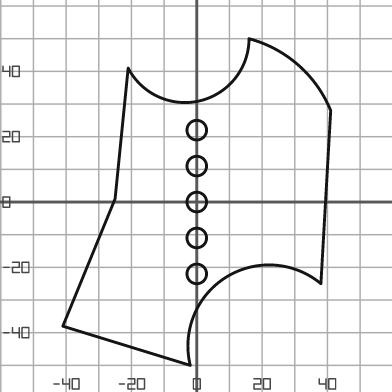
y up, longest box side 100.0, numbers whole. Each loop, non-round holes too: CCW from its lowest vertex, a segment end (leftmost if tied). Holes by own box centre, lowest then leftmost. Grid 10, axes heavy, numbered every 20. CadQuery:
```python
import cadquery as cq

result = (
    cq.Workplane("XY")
    .moveTo(-2.0, -50.0)
    .threePointArc((9.0, -23.0), (38.0, -25.0))
    .lineTo(41.0, 28.0)
    .threePointArc((31.0, 42.0), (16.0, 50.0))
    .threePointArc((1.0, 31.0), (-21.0, 41.0))
    .lineTo(-25.0, 1.0)
    .lineTo(-41.0, -38.0)
    .close()
    .moveTo(0.0, -22.0)
    .circle(3.0)
    .moveTo(0.0, -11.0)
    .circle(3.0)
    .moveTo(0.0, 0.0)
    .circle(3.0)
    .moveTo(0.0, 11.0)
    .circle(3.0)
    .moveTo(0.0, 22.0)
    .circle(3.0)
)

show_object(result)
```